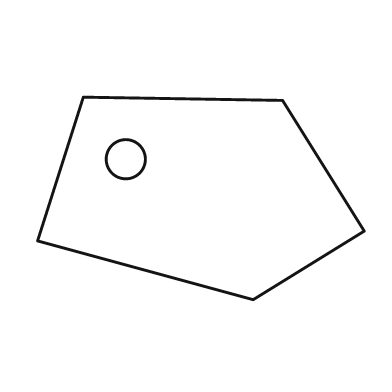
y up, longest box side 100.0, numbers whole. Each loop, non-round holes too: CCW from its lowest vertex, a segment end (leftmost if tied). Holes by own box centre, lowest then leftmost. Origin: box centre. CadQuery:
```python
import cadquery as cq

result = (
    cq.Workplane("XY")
    .moveTo(16.0, -31.0)
    .lineTo(50.0, -10.0)
    .lineTo(25.0, 30.0)
    .lineTo(-36.0, 31.0)
    .lineTo(-50.0, -13.0)
    .close()
    .moveTo(-23.0, 12.0)
    .circle(6.0)
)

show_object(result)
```